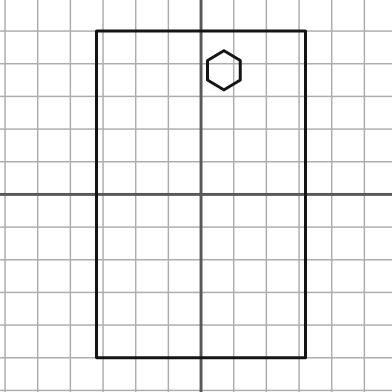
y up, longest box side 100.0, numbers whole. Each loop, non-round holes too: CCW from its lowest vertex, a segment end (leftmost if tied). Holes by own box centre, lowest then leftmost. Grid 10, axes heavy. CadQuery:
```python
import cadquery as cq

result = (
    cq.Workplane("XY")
    .moveTo(-32.0, -50.0)
    .lineTo(32.0, -50.0)
    .lineTo(32.0, 50.0)
    .lineTo(-32.0, 50.0)
    .close()
    .moveTo(7.0, 32.0)
    .lineTo(12.0, 35.0)
    .lineTo(12.0, 41.0)
    .lineTo(7.0, 44.0)
    .lineTo(2.0, 41.0)
    .lineTo(2.0, 35.0)
    .close()
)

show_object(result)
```